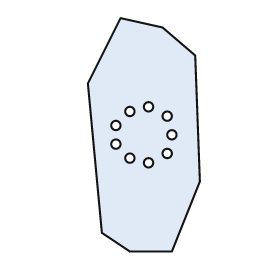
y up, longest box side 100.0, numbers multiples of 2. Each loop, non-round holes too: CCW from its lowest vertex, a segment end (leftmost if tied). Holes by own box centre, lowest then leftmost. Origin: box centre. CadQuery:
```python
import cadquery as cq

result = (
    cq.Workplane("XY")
    .moveTo(-6.0, -50.0)
    .lineTo(12.0, -50.0)
    .lineTo(24.0, -20.0)
    .lineTo(22.0, 34.0)
    .lineTo(8.0, 46.0)
    .lineTo(-10.0, 50.0)
    .lineTo(-24.0, 22.0)
    .lineTo(-18.0, -42.0)
    .close()
    .moveTo(2.0, -12.0)
    .circle(2.0)
    .moveTo(-6.0, -10.0)
    .circle(2.0)
    .moveTo(10.0, -8.0)
    .circle(2.0)
    .moveTo(-12.0, -4.0)
    .circle(2.0)
    .moveTo(12.0, 0.0)
    .circle(2.0)
    .moveTo(-12.0, 4.0)
    .circle(2.0)
    .moveTo(10.0, 8.0)
    .circle(2.0)
    .moveTo(-6.0, 10.0)
    .circle(2.0)
    .moveTo(2.0, 12.0)
    .circle(2.0)
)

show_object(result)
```